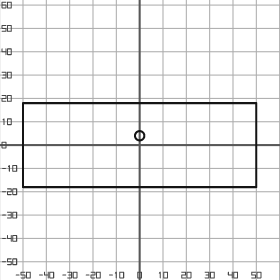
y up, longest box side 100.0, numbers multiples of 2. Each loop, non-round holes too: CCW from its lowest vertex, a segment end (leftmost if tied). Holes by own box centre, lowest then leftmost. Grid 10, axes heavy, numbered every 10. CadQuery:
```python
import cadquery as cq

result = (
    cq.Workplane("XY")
    .moveTo(-50.0, -18.0)
    .lineTo(50.0, -18.0)
    .lineTo(50.0, 18.0)
    .lineTo(-50.0, 18.0)
    .close()
    .moveTo(0.0, 4.0)
    .circle(2.0)
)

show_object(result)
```